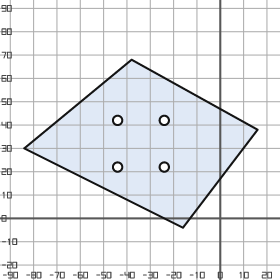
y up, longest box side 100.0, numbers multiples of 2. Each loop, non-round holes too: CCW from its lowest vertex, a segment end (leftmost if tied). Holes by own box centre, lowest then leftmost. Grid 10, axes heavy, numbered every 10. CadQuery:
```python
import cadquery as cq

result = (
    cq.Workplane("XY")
    .moveTo(-16.0, -4.0)
    .lineTo(16.0, 38.0)
    .lineTo(-38.0, 68.0)
    .lineTo(-84.0, 30.0)
    .close()
    .moveTo(-44.0, 22.0)
    .circle(2.0)
    .moveTo(-24.0, 22.0)
    .circle(2.0)
    .moveTo(-44.0, 42.0)
    .circle(2.0)
    .moveTo(-24.0, 42.0)
    .circle(2.0)
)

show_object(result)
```